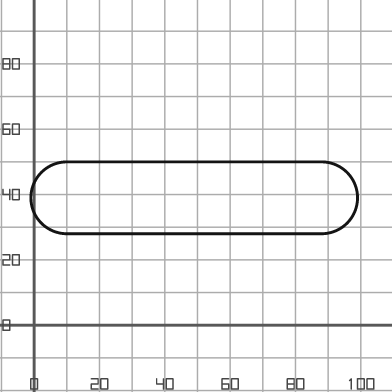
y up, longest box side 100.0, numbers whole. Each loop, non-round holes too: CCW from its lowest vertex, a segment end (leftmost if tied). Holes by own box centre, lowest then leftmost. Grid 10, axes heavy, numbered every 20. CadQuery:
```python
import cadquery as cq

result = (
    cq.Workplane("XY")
    .moveTo(10.0, 28.0)
    .lineTo(88.0, 28.0)
    .threePointArc((99.0, 39.0), (88.0, 50.0))
    .lineTo(10.0, 50.0)
    .threePointArc((-1.0, 39.0), (10.0, 28.0))
    .close()
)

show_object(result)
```